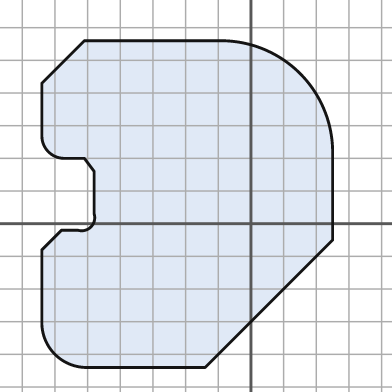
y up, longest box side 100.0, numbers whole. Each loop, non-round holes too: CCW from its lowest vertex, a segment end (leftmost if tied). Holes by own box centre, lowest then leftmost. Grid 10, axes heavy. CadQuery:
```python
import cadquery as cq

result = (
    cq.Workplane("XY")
    .moveTo(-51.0, -44.0)
    .lineTo(-14.0, -44.0)
    .lineTo(25.0, -5.0)
    .lineTo(25.0, 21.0)
    .threePointArc((15.0, 46.0), (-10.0, 56.0))
    .lineTo(-51.0, 56.0)
    .lineTo(-64.0, 43.0)
    .lineTo(-64.0, 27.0)
    .threePointArc((-62.0, 22.0), (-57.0, 20.0))
    .lineTo(-51.0, 20.0)
    .lineTo(-48.0, 16.0)
    .lineTo(-48.0, 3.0)
    .threePointArc((-49.0, -1.0), (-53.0, -2.0))
    .lineTo(-58.0, -2.0)
    .lineTo(-64.0, -8.0)
    .lineTo(-64.0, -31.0)
    .threePointArc((-60.0, -40.0), (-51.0, -44.0))
    .close()
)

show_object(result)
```